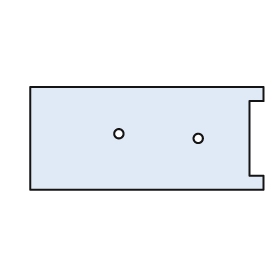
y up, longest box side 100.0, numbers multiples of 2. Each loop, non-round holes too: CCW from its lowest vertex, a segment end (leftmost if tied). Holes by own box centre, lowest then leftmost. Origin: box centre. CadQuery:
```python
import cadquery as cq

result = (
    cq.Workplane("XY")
    .moveTo(-50.0, -22.0)
    .lineTo(50.0, -22.0)
    .lineTo(50.0, -16.0)
    .lineTo(44.0, -16.0)
    .lineTo(44.0, 16.0)
    .lineTo(50.0, 16.0)
    .lineTo(50.0, 22.0)
    .lineTo(-50.0, 22.0)
    .close()
    .moveTo(22.0, 0.0)
    .circle(2.0)
    .moveTo(-12.0, 2.0)
    .circle(2.0)
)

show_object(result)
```